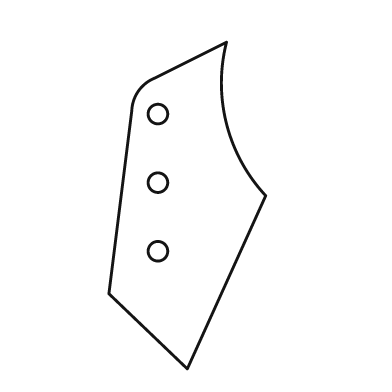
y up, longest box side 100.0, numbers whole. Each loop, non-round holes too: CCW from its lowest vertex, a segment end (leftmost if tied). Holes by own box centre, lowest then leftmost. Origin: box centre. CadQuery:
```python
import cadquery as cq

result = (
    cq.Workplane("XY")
    .moveTo(0.0, -50.0)
    .lineTo(24.0, 3.0)
    .threePointArc((12.0, 25.0), (12.0, 50.0))
    .lineTo(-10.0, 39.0)
    .threePointArc((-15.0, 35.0), (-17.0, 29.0))
    .lineTo(-24.0, -27.0)
    .close()
    .moveTo(-9.0, -14.0)
    .circle(3.0)
    .moveTo(-9.0, 7.0)
    .circle(3.0)
    .moveTo(-9.0, 28.0)
    .circle(3.0)
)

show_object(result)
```